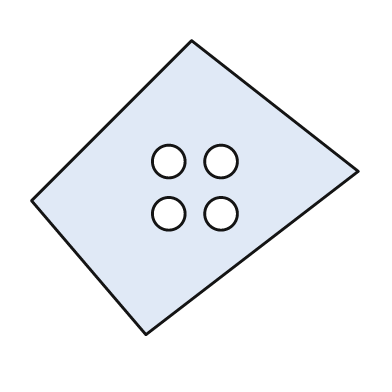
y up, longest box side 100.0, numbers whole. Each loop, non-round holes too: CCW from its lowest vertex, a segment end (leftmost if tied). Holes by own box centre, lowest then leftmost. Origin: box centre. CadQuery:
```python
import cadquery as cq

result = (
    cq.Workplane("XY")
    .moveTo(-15.0, -45.0)
    .lineTo(50.0, 5.0)
    .lineTo(-1.0, 45.0)
    .lineTo(-50.0, -4.0)
    .close()
    .moveTo(-8.0, -8.0)
    .circle(5.0)
    .moveTo(8.0, -8.0)
    .circle(5.0)
    .moveTo(-8.0, 8.0)
    .circle(5.0)
    .moveTo(8.0, 8.0)
    .circle(5.0)
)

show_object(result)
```